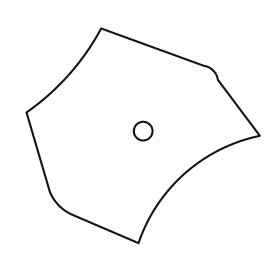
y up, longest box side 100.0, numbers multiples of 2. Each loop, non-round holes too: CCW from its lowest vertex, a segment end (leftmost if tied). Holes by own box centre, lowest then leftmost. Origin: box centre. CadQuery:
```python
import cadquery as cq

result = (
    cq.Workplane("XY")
    .moveTo(-2.0, -46.0)
    .threePointArc((18.0, -16.0), (50.0, 0.0))
    .lineTo(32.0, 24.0)
    .threePointArc((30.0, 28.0), (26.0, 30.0))
    .lineTo(-18.0, 46.0)
    .threePointArc((-32.0, 26.0), (-50.0, 10.0))
    .lineTo(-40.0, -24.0)
    .threePointArc((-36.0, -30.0), (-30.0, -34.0))
    .close()
    .moveTo(0.0, 2.0)
    .circle(4.0)
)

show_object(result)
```